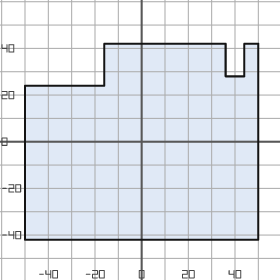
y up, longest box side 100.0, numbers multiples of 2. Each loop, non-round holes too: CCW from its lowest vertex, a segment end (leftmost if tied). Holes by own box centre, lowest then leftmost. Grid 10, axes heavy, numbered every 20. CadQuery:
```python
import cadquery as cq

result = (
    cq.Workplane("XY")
    .moveTo(-50.0, -42.0)
    .lineTo(50.0, -42.0)
    .lineTo(50.0, 42.0)
    .lineTo(44.0, 42.0)
    .lineTo(44.0, 28.0)
    .lineTo(36.0, 28.0)
    .lineTo(36.0, 42.0)
    .lineTo(-16.0, 42.0)
    .lineTo(-16.0, 24.0)
    .lineTo(-50.0, 24.0)
    .close()
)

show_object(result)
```